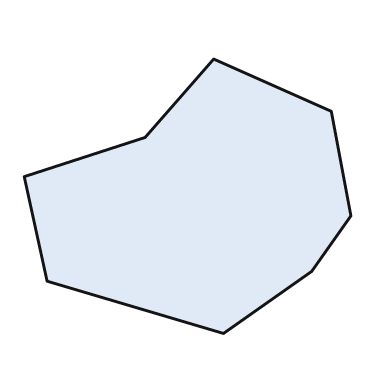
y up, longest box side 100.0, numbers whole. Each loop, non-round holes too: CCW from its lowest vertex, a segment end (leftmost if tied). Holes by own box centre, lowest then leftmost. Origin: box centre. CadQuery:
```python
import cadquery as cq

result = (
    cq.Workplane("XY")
    .moveTo(11.0, -42.0)
    .lineTo(38.0, -23.0)
    .lineTo(50.0, -6.0)
    .lineTo(44.0, 26.0)
    .lineTo(8.0, 42.0)
    .lineTo(-13.0, 18.0)
    .lineTo(-50.0, 6.0)
    .lineTo(-43.0, -26.0)
    .close()
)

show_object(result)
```